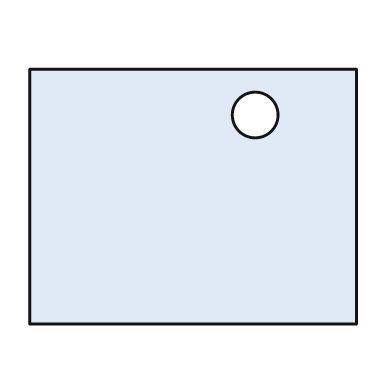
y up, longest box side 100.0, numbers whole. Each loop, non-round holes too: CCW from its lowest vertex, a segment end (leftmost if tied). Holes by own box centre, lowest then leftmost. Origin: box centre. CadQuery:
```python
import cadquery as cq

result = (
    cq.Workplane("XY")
    .moveTo(-50.0, -39.0)
    .lineTo(50.0, -39.0)
    .lineTo(50.0, 39.0)
    .lineTo(-50.0, 39.0)
    .close()
    .moveTo(19.0, 25.0)
    .circle(7.0)
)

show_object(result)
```